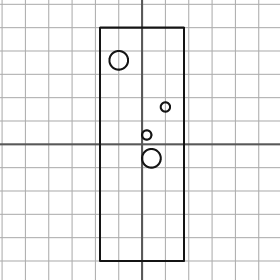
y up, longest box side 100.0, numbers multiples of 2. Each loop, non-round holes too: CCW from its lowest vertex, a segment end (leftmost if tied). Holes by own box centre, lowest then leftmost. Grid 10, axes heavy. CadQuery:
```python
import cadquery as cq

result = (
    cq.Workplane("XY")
    .moveTo(-18.0, -50.0)
    .lineTo(18.0, -50.0)
    .lineTo(18.0, 50.0)
    .lineTo(-18.0, 50.0)
    .close()
    .moveTo(4.0, -6.0)
    .circle(4.0)
    .moveTo(2.0, 4.0)
    .circle(2.0)
    .moveTo(10.0, 16.0)
    .circle(2.0)
    .moveTo(-10.0, 36.0)
    .circle(4.0)
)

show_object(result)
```